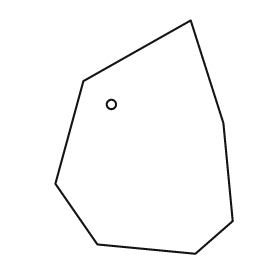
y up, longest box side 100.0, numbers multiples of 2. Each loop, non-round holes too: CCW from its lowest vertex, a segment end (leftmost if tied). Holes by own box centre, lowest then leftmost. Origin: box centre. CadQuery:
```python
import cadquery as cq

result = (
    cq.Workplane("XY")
    .moveTo(22.0, -50.0)
    .lineTo(38.0, -36.0)
    .lineTo(34.0, 6.0)
    .lineTo(20.0, 50.0)
    .lineTo(-26.0, 24.0)
    .lineTo(-38.0, -20.0)
    .lineTo(-20.0, -46.0)
    .close()
    .moveTo(-14.0, 14.0)
    .circle(2.0)
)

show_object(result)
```